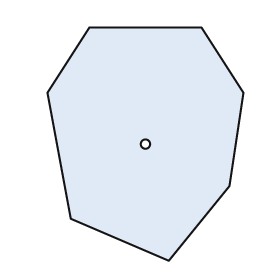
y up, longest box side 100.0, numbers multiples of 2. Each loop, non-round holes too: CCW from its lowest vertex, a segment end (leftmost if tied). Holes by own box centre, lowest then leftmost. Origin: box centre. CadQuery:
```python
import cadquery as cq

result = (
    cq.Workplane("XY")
    .moveTo(10.0, -50.0)
    .lineTo(36.0, -18.0)
    .lineTo(42.0, 22.0)
    .lineTo(24.0, 50.0)
    .lineTo(-24.0, 50.0)
    .lineTo(-42.0, 22.0)
    .lineTo(-32.0, -32.0)
    .close()
    .moveTo(0.0, 0.0)
    .circle(2.0)
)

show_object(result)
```